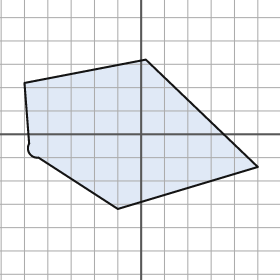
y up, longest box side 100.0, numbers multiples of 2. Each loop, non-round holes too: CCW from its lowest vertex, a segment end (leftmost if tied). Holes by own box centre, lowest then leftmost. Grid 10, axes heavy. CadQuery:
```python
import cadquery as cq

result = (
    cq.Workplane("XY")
    .moveTo(-10.0, -32.0)
    .lineTo(50.0, -14.0)
    .lineTo(2.0, 32.0)
    .lineTo(-50.0, 22.0)
    .lineTo(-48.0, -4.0)
    .threePointArc((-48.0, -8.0), (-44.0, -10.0))
    .close()
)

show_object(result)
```